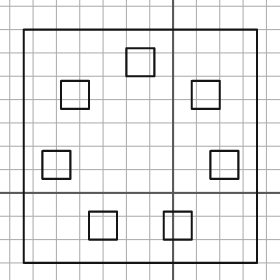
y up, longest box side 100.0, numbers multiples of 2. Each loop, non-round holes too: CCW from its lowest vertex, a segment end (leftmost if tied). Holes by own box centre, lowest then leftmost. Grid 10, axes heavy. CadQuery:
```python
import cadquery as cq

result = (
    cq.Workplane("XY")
    .moveTo(-64.0, -30.0)
    .lineTo(36.0, -30.0)
    .lineTo(36.0, 70.0)
    .lineTo(-64.0, 70.0)
    .close()
    .moveTo(-36.0, -20.0)
    .lineTo(-24.0, -20.0)
    .lineTo(-24.0, -8.0)
    .lineTo(-36.0, -8.0)
    .close()
    .moveTo(-4.0, -20.0)
    .lineTo(8.0, -20.0)
    .lineTo(8.0, -8.0)
    .lineTo(-4.0, -8.0)
    .close()
    .moveTo(-56.0, 6.0)
    .lineTo(-44.0, 6.0)
    .lineTo(-44.0, 18.0)
    .lineTo(-56.0, 18.0)
    .close()
    .moveTo(16.0, 6.0)
    .lineTo(28.0, 6.0)
    .lineTo(28.0, 18.0)
    .lineTo(16.0, 18.0)
    .close()
    .moveTo(-48.0, 36.0)
    .lineTo(-36.0, 36.0)
    .lineTo(-36.0, 48.0)
    .lineTo(-48.0, 48.0)
    .close()
    .moveTo(8.0, 36.0)
    .lineTo(20.0, 36.0)
    .lineTo(20.0, 48.0)
    .lineTo(8.0, 48.0)
    .close()
    .moveTo(-20.0, 50.0)
    .lineTo(-8.0, 50.0)
    .lineTo(-8.0, 62.0)
    .lineTo(-20.0, 62.0)
    .close()
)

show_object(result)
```